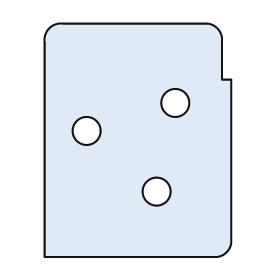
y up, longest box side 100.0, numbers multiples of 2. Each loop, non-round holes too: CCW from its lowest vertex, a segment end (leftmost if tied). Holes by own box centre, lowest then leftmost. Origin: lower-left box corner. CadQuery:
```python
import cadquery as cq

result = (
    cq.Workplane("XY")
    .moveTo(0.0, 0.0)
    .lineTo(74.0, 0.0)
    .threePointArc((78.0, 2.0), (80.0, 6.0))
    .lineTo(80.0, 76.0)
    .lineTo(76.0, 76.0)
    .lineTo(76.0, 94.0)
    .threePointArc((74.0, 98.0), (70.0, 100.0))
    .lineTo(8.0, 100.0)
    .threePointArc((2.0, 98.0), (0.0, 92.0))
    .close()
    .moveTo(48.0, 28.0)
    .circle(6.0)
    .moveTo(18.0, 54.0)
    .circle(6.0)
    .moveTo(56.0, 66.0)
    .circle(6.0)
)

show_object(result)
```